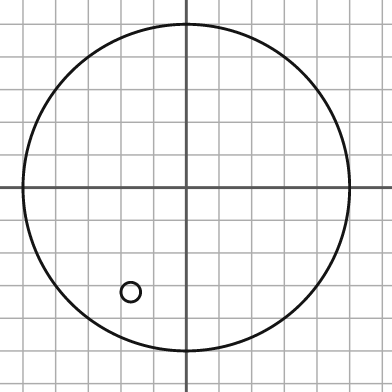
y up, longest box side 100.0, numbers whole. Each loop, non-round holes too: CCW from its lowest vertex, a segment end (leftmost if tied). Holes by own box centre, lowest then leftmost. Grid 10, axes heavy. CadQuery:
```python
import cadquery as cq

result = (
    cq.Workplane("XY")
    .moveTo(0.0, 0.0)
    .circle(50.0)
    .moveTo(-17.0, -32.0)
    .circle(3.0)
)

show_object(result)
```